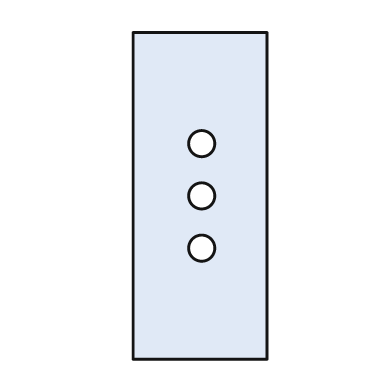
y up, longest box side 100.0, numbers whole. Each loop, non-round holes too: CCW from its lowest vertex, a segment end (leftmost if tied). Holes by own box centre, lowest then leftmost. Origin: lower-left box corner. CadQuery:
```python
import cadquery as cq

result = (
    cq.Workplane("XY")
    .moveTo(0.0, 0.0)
    .lineTo(41.0, 0.0)
    .lineTo(41.0, 100.0)
    .lineTo(0.0, 100.0)
    .close()
    .moveTo(21.0, 34.0)
    .circle(4.0)
    .moveTo(21.0, 50.0)
    .circle(4.0)
    .moveTo(21.0, 66.0)
    .circle(4.0)
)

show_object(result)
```